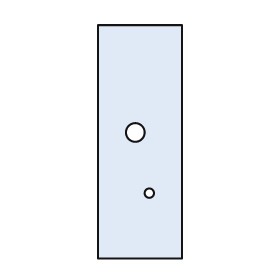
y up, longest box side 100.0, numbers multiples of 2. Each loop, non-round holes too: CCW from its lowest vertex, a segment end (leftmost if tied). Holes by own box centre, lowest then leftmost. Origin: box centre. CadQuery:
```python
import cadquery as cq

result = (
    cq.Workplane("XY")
    .moveTo(-18.0, -50.0)
    .lineTo(18.0, -50.0)
    .lineTo(18.0, 50.0)
    .lineTo(-18.0, 50.0)
    .close()
    .moveTo(4.0, -22.0)
    .circle(2.0)
    .moveTo(-2.0, 4.0)
    .circle(4.0)
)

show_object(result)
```